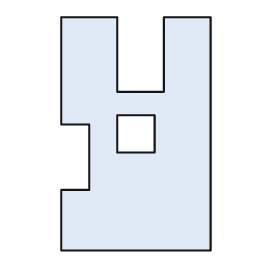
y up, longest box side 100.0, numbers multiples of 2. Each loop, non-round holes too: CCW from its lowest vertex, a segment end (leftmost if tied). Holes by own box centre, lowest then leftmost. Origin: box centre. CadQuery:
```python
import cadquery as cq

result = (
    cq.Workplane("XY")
    .moveTo(-32.0, -50.0)
    .lineTo(32.0, -50.0)
    .lineTo(32.0, 50.0)
    .lineTo(12.0, 50.0)
    .lineTo(12.0, 18.0)
    .lineTo(-8.0, 18.0)
    .lineTo(-8.0, 50.0)
    .lineTo(-32.0, 50.0)
    .lineTo(-32.0, 4.0)
    .lineTo(-20.0, 4.0)
    .lineTo(-20.0, -24.0)
    .lineTo(-32.0, -24.0)
    .close()
    .moveTo(-8.0, -8.0)
    .lineTo(8.0, -8.0)
    .lineTo(8.0, 8.0)
    .lineTo(-8.0, 8.0)
    .close()
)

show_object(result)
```